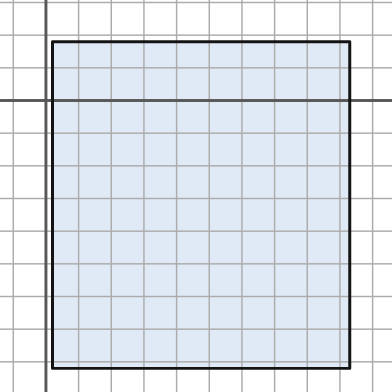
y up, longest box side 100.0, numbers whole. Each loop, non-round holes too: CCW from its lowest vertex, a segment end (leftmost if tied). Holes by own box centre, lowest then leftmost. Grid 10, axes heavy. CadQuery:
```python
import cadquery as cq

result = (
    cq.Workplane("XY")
    .moveTo(2.0, -82.0)
    .lineTo(93.0, -82.0)
    .lineTo(93.0, 18.0)
    .lineTo(2.0, 18.0)
    .close()
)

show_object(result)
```